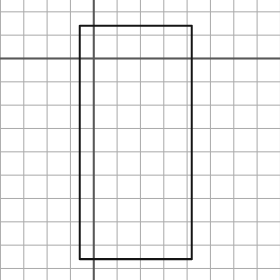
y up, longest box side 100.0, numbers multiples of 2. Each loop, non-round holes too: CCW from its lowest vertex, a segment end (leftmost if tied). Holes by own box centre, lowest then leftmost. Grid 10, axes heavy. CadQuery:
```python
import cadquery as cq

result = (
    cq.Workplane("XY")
    .moveTo(-6.0, -86.0)
    .lineTo(42.0, -86.0)
    .lineTo(42.0, 14.0)
    .lineTo(-6.0, 14.0)
    .close()
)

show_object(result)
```